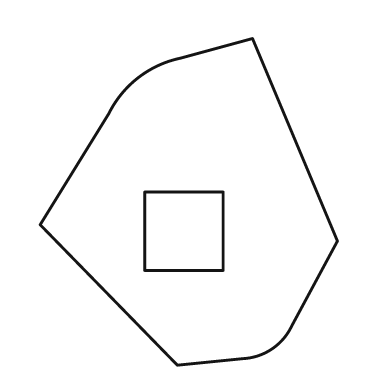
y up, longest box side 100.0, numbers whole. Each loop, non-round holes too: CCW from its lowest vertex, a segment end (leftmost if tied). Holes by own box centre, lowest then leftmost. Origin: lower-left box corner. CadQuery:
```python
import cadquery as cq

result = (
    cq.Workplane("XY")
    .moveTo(42.0, 0.0)
    .lineTo(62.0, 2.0)
    .threePointArc((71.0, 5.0), (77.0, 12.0))
    .lineTo(91.0, 38.0)
    .lineTo(65.0, 100.0)
    .lineTo(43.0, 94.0)
    .threePointArc((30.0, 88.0), (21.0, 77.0))
    .lineTo(0.0, 43.0)
    .close()
    .moveTo(32.0, 29.0)
    .lineTo(56.0, 29.0)
    .lineTo(56.0, 53.0)
    .lineTo(32.0, 53.0)
    .close()
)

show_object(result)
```